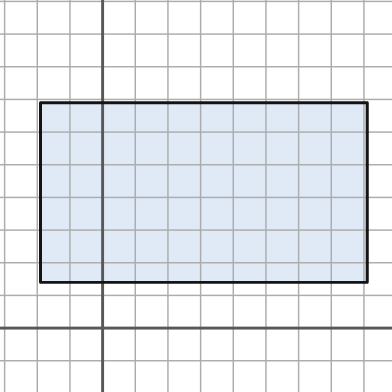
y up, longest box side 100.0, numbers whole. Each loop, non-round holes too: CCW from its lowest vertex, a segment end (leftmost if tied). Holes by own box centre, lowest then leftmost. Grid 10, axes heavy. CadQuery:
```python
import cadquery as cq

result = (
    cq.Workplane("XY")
    .moveTo(-19.0, 14.0)
    .lineTo(81.0, 14.0)
    .lineTo(81.0, 69.0)
    .lineTo(-19.0, 69.0)
    .close()
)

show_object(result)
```